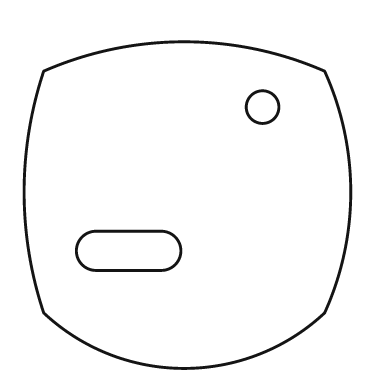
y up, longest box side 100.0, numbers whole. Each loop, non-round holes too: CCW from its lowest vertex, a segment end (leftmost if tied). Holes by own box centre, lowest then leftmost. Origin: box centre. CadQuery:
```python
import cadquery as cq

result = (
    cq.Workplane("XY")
    .moveTo(-44.0, -33.0)
    .threePointArc((-1.0, -50.0), (42.0, -33.0))
    .threePointArc((50.0, 4.0), (42.0, 41.0))
    .threePointArc((-1.0, 50.0), (-44.0, 41.0))
    .threePointArc((-50.0, 4.0), (-44.0, -33.0))
    .close()
    .moveTo(-28.0, -20.0)
    .lineTo(-8.0, -20.0)
    .threePointArc((-2.0, -14.0), (-8.0, -8.0))
    .lineTo(-28.0, -8.0)
    .threePointArc((-34.0, -14.0), (-28.0, -20.0))
    .close()
    .moveTo(23.0, 30.0)
    .circle(5.0)
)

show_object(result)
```